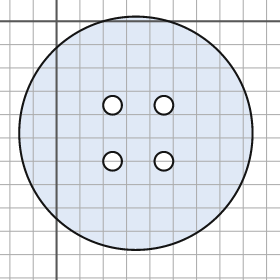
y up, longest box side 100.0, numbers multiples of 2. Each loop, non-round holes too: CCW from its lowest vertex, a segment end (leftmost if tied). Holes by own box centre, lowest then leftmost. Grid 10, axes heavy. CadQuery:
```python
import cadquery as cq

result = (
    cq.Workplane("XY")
    .moveTo(34.0, -48.0)
    .circle(50.0)
    .moveTo(24.0, -60.0)
    .circle(4.0)
    .moveTo(46.0, -60.0)
    .circle(4.0)
    .moveTo(24.0, -36.0)
    .circle(4.0)
    .moveTo(46.0, -36.0)
    .circle(4.0)
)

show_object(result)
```